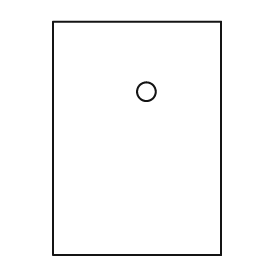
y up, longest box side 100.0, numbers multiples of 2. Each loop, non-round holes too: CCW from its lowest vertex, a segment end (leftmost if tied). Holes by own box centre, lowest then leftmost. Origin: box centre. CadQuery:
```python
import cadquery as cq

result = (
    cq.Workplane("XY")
    .moveTo(-36.0, -50.0)
    .lineTo(36.0, -50.0)
    .lineTo(36.0, 50.0)
    .lineTo(-36.0, 50.0)
    .close()
    .moveTo(4.0, 20.0)
    .circle(4.0)
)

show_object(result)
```